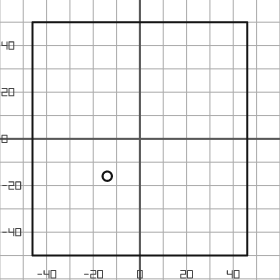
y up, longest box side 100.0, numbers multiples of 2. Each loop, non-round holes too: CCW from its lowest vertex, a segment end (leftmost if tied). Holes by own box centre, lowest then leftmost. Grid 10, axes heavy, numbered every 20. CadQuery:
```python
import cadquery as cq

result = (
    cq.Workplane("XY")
    .moveTo(-46.0, -50.0)
    .lineTo(46.0, -50.0)
    .lineTo(46.0, 50.0)
    .lineTo(-46.0, 50.0)
    .close()
    .moveTo(-14.0, -16.0)
    .circle(2.0)
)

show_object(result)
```